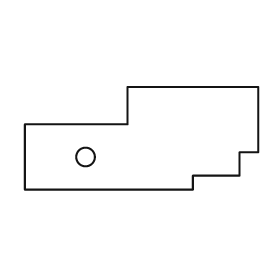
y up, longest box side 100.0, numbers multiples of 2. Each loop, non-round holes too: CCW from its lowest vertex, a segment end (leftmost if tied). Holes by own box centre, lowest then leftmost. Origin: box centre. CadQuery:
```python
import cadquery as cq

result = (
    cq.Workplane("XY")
    .moveTo(-50.0, -22.0)
    .lineTo(22.0, -22.0)
    .lineTo(22.0, -16.0)
    .lineTo(42.0, -16.0)
    .lineTo(42.0, -6.0)
    .lineTo(50.0, -6.0)
    .lineTo(50.0, 22.0)
    .lineTo(-6.0, 22.0)
    .lineTo(-6.0, 6.0)
    .lineTo(-50.0, 6.0)
    .close()
    .moveTo(-24.0, -8.0)
    .circle(4.0)
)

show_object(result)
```